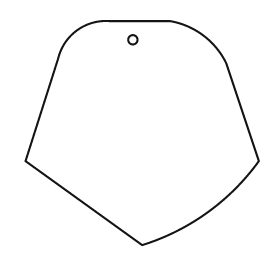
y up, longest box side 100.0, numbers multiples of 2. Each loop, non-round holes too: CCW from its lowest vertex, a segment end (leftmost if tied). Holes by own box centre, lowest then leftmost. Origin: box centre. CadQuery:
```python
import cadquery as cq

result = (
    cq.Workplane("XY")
    .moveTo(0.0, -48.0)
    .threePointArc((28.0, -34.0), (50.0, -12.0))
    .lineTo(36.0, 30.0)
    .threePointArc((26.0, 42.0), (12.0, 48.0))
    .lineTo(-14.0, 48.0)
    .threePointArc((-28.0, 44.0), (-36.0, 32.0))
    .lineTo(-50.0, -12.0)
    .close()
    .moveTo(-4.0, 40.0)
    .circle(2.0)
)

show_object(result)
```